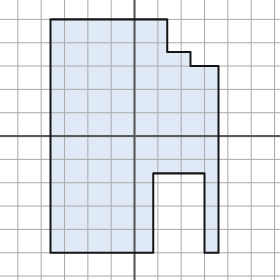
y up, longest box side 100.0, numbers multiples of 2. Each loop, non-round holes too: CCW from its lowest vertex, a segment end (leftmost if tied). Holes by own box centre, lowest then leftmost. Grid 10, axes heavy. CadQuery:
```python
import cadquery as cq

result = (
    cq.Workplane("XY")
    .moveTo(-36.0, -50.0)
    .lineTo(8.0, -50.0)
    .lineTo(8.0, -16.0)
    .lineTo(30.0, -16.0)
    .lineTo(30.0, -50.0)
    .lineTo(36.0, -50.0)
    .lineTo(36.0, 30.0)
    .lineTo(24.0, 30.0)
    .lineTo(24.0, 36.0)
    .lineTo(14.0, 36.0)
    .lineTo(14.0, 50.0)
    .lineTo(-36.0, 50.0)
    .close()
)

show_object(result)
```